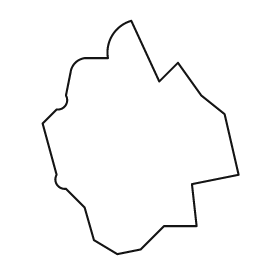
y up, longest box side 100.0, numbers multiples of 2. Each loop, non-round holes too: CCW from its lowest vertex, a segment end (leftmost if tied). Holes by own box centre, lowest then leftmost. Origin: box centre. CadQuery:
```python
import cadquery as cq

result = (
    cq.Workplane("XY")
    .moveTo(-10.0, -50.0)
    .lineTo(0.0, -48.0)
    .lineTo(10.0, -38.0)
    .lineTo(24.0, -38.0)
    .lineTo(22.0, -20.0)
    .lineTo(42.0, -16.0)
    .lineTo(36.0, 10.0)
    .lineTo(26.0, 18.0)
    .lineTo(16.0, 32.0)
    .lineTo(8.0, 24.0)
    .lineTo(-4.0, 50.0)
    .threePointArc((-12.0, 44.0), (-14.0, 34.0))
    .lineTo(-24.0, 34.0)
    .threePointArc((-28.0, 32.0), (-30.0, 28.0))
    .lineTo(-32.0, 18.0)
    .threePointArc((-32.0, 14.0), (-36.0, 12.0))
    .lineTo(-42.0, 6.0)
    .lineTo(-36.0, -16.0)
    .threePointArc((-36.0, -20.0), (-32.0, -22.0))
    .lineTo(-24.0, -30.0)
    .lineTo(-20.0, -44.0)
    .close()
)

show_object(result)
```